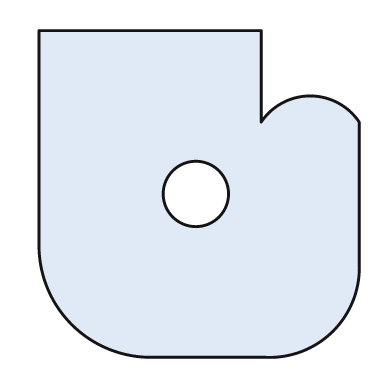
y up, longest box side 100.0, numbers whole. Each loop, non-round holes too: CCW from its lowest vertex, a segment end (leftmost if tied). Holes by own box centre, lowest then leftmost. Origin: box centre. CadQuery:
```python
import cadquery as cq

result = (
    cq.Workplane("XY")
    .moveTo(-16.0, -50.0)
    .lineTo(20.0, -50.0)
    .threePointArc((41.0, -42.0), (49.0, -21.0))
    .lineTo(49.0, 22.0)
    .threePointArc((34.0, 30.0), (19.0, 22.0))
    .lineTo(19.0, 50.0)
    .lineTo(-49.0, 50.0)
    .lineTo(-49.0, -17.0)
    .threePointArc((-39.0, -40.0), (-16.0, -50.0))
    .close()
    .moveTo(-1.0, 0.0)
    .circle(10.0)
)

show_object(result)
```